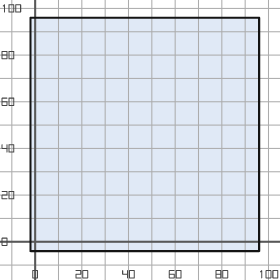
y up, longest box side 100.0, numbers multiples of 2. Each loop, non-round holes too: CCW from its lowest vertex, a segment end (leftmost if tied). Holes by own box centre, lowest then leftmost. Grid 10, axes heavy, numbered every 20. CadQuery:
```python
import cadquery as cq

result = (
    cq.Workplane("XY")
    .moveTo(-2.0, -4.0)
    .lineTo(96.0, -4.0)
    .lineTo(96.0, 96.0)
    .lineTo(-2.0, 96.0)
    .close()
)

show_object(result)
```